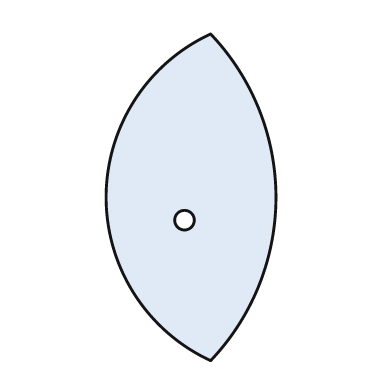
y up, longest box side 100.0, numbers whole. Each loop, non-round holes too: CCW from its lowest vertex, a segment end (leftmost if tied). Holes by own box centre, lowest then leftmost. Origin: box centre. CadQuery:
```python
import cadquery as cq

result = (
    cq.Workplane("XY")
    .moveTo(6.0, -50.0)
    .threePointArc((26.0, 0.0), (6.0, 50.0))
    .threePointArc((-26.0, 0.0), (6.0, -50.0))
    .close()
    .moveTo(-2.0, -7.0)
    .circle(3.0)
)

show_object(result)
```